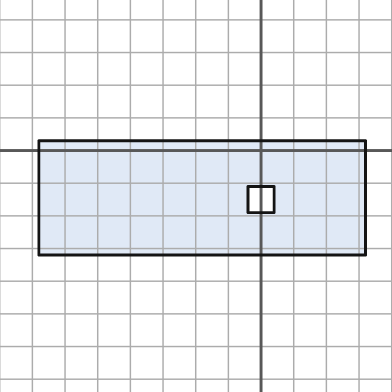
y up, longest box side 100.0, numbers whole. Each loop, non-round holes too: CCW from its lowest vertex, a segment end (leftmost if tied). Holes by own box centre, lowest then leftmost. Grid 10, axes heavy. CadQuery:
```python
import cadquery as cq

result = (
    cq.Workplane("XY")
    .moveTo(-68.0, -32.0)
    .lineTo(32.0, -32.0)
    .lineTo(32.0, 3.0)
    .lineTo(-68.0, 3.0)
    .close()
    .moveTo(-4.0, -19.0)
    .lineTo(4.0, -19.0)
    .lineTo(4.0, -11.0)
    .lineTo(-4.0, -11.0)
    .close()
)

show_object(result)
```